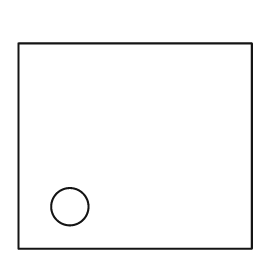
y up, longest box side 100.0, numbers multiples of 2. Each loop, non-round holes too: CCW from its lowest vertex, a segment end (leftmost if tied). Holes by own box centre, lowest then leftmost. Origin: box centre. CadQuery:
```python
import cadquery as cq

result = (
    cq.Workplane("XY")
    .moveTo(-50.0, -44.0)
    .lineTo(50.0, -44.0)
    .lineTo(50.0, 44.0)
    .lineTo(-50.0, 44.0)
    .close()
    .moveTo(-28.0, -26.0)
    .circle(8.0)
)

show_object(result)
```